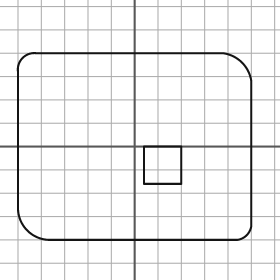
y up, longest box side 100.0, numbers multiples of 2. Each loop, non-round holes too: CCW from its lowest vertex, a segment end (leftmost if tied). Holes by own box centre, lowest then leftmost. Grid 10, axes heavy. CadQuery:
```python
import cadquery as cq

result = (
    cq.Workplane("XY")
    .moveTo(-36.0, -40.0)
    .lineTo(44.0, -40.0)
    .threePointArc((48.0, -38.0), (50.0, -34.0))
    .lineTo(50.0, 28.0)
    .threePointArc((46.0, 36.0), (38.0, 40.0))
    .lineTo(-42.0, 40.0)
    .threePointArc((-48.0, 38.0), (-50.0, 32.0))
    .lineTo(-50.0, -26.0)
    .threePointArc((-46.0, -36.0), (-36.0, -40.0))
    .close()
    .moveTo(4.0, -16.0)
    .lineTo(20.0, -16.0)
    .lineTo(20.0, 0.0)
    .lineTo(4.0, 0.0)
    .close()
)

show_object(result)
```